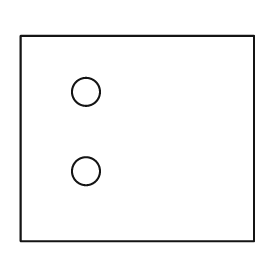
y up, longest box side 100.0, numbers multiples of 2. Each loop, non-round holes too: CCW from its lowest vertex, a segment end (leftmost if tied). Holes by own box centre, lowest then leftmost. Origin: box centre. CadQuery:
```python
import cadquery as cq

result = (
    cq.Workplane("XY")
    .moveTo(-50.0, -44.0)
    .lineTo(50.0, -44.0)
    .lineTo(50.0, 44.0)
    .lineTo(-50.0, 44.0)
    .close()
    .moveTo(-22.0, -14.0)
    .circle(6.0)
    .moveTo(-22.0, 20.0)
    .circle(6.0)
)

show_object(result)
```